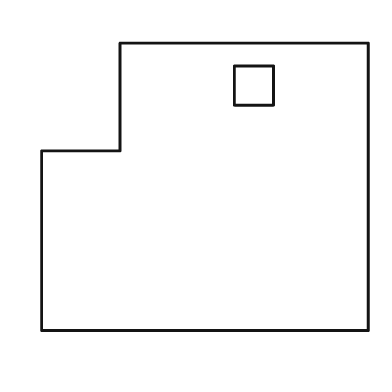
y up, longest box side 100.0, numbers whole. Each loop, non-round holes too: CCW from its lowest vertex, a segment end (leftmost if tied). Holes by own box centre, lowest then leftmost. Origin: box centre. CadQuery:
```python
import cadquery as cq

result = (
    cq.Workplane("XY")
    .moveTo(-50.0, -44.0)
    .lineTo(50.0, -44.0)
    .lineTo(50.0, 44.0)
    .lineTo(-26.0, 44.0)
    .lineTo(-26.0, 11.0)
    .lineTo(-50.0, 11.0)
    .close()
    .moveTo(9.0, 25.0)
    .lineTo(21.0, 25.0)
    .lineTo(21.0, 37.0)
    .lineTo(9.0, 37.0)
    .close()
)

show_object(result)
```